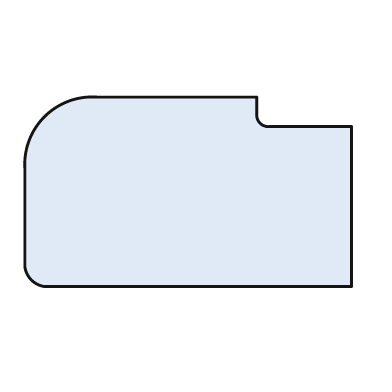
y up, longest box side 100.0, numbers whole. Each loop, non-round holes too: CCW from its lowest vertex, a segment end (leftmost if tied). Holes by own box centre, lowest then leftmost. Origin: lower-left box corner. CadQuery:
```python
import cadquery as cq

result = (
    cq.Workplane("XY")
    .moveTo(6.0, 0.0)
    .lineTo(100.0, 0.0)
    .lineTo(100.0, 49.0)
    .lineTo(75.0, 49.0)
    .threePointArc((72.0, 50.0), (71.0, 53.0))
    .lineTo(71.0, 58.0)
    .lineTo(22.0, 58.0)
    .threePointArc((6.0, 52.0), (0.0, 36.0))
    .lineTo(0.0, 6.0)
    .threePointArc((2.0, 2.0), (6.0, 0.0))
    .close()
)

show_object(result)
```